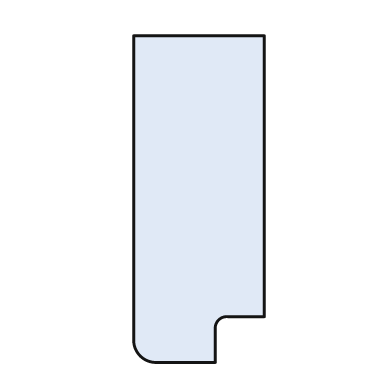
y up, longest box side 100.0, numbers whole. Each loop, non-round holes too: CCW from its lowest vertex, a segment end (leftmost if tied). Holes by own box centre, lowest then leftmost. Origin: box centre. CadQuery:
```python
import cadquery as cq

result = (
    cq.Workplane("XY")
    .moveTo(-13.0, -50.0)
    .lineTo(5.0, -50.0)
    .lineTo(5.0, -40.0)
    .threePointArc((6.0, -37.0), (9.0, -36.0))
    .lineTo(20.0, -36.0)
    .lineTo(20.0, 50.0)
    .lineTo(-20.0, 50.0)
    .lineTo(-20.0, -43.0)
    .threePointArc((-18.0, -48.0), (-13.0, -50.0))
    .close()
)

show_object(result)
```